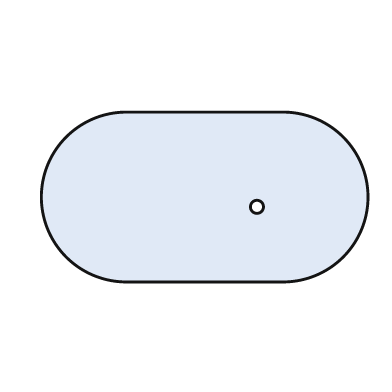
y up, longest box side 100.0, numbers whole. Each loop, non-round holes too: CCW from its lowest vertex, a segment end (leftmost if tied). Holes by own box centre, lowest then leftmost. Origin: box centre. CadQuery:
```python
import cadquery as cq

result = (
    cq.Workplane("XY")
    .moveTo(-24.0, -26.0)
    .lineTo(24.0, -26.0)
    .threePointArc((50.0, 0.0), (24.0, 26.0))
    .lineTo(-24.0, 26.0)
    .threePointArc((-50.0, 0.0), (-24.0, -26.0))
    .close()
    .moveTo(16.0, -3.0)
    .circle(2.0)
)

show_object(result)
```